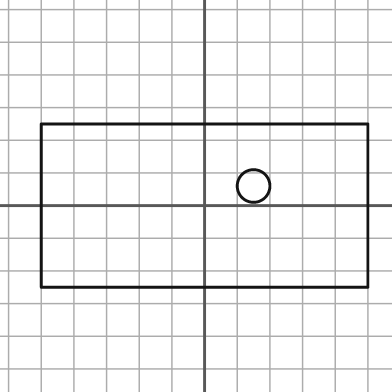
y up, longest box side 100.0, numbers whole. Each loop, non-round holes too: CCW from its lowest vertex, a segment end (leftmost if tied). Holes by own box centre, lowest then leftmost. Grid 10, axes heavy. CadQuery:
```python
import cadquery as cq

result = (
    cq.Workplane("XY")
    .moveTo(-50.0, -25.0)
    .lineTo(50.0, -25.0)
    .lineTo(50.0, 25.0)
    .lineTo(-50.0, 25.0)
    .close()
    .moveTo(15.0, 6.0)
    .circle(5.0)
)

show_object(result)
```